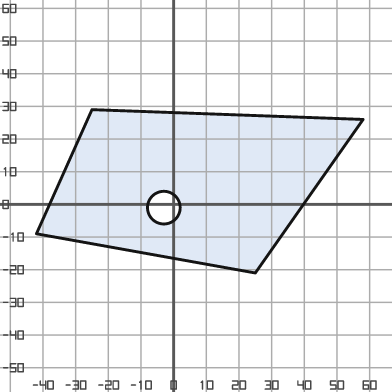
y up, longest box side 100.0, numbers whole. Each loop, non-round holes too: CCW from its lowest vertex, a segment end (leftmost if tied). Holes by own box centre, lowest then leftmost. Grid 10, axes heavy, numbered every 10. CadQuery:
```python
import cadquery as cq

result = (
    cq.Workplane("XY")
    .moveTo(25.0, -21.0)
    .lineTo(58.0, 26.0)
    .lineTo(-25.0, 29.0)
    .lineTo(-42.0, -9.0)
    .close()
    .moveTo(-3.0, -1.0)
    .circle(5.0)
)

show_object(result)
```